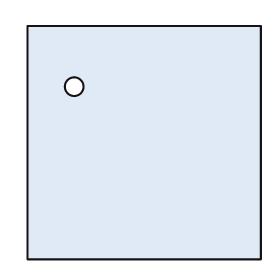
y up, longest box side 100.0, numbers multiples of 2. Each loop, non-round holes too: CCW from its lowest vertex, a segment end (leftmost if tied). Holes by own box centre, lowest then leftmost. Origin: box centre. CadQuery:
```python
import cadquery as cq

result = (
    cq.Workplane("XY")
    .moveTo(-50.0, -50.0)
    .lineTo(50.0, -50.0)
    .lineTo(50.0, 50.0)
    .lineTo(-50.0, 50.0)
    .close()
    .moveTo(-30.0, 24.0)
    .circle(4.0)
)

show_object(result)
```